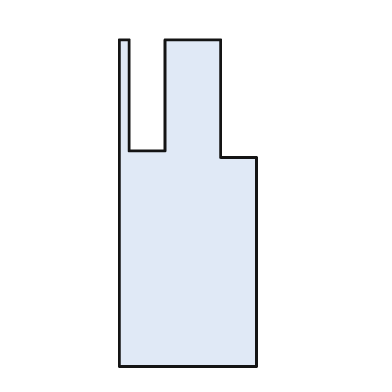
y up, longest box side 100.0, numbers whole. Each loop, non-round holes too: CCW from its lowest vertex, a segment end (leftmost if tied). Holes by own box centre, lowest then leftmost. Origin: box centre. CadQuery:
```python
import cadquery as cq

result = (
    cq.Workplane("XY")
    .moveTo(-21.0, -50.0)
    .lineTo(21.0, -50.0)
    .lineTo(21.0, 14.0)
    .lineTo(10.0, 14.0)
    .lineTo(10.0, 50.0)
    .lineTo(-7.0, 50.0)
    .lineTo(-7.0, 16.0)
    .lineTo(-18.0, 16.0)
    .lineTo(-18.0, 50.0)
    .lineTo(-21.0, 50.0)
    .close()
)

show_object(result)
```